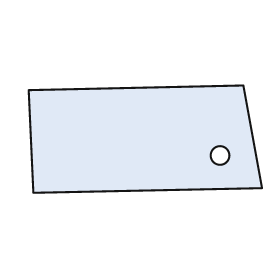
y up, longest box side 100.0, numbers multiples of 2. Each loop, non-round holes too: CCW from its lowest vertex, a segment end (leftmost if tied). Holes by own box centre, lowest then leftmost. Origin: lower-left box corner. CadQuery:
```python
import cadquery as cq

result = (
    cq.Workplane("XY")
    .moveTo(2.0, 0.0)
    .lineTo(100.0, 2.0)
    .lineTo(92.0, 46.0)
    .lineTo(0.0, 44.0)
    .close()
    .moveTo(82.0, 16.0)
    .circle(4.0)
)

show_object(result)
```